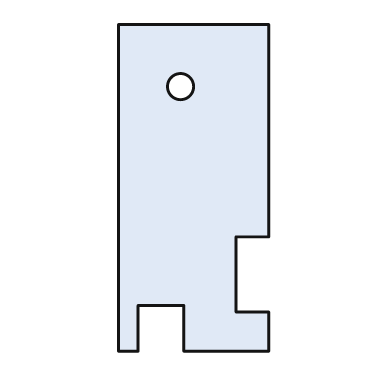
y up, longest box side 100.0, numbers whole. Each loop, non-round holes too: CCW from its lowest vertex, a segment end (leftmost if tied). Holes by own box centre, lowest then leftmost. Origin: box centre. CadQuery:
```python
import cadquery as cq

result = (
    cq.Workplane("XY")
    .moveTo(-23.0, -50.0)
    .lineTo(-17.0, -50.0)
    .lineTo(-17.0, -36.0)
    .lineTo(-3.0, -36.0)
    .lineTo(-3.0, -50.0)
    .lineTo(23.0, -50.0)
    .lineTo(23.0, -38.0)
    .lineTo(13.0, -38.0)
    .lineTo(13.0, -15.0)
    .lineTo(23.0, -15.0)
    .lineTo(23.0, 50.0)
    .lineTo(-23.0, 50.0)
    .close()
    .moveTo(-4.0, 31.0)
    .circle(4.0)
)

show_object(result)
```